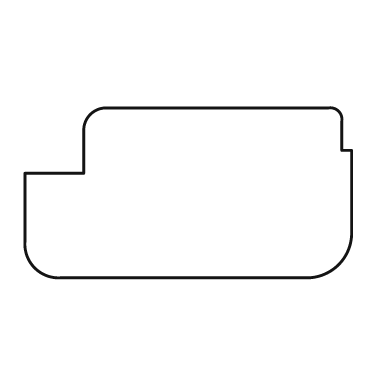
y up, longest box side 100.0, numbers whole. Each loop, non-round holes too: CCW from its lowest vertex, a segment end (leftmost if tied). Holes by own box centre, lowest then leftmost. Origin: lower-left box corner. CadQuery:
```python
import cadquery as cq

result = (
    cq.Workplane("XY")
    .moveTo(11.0, 0.0)
    .lineTo(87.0, 0.0)
    .threePointArc((96.0, 4.0), (100.0, 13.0))
    .lineTo(100.0, 39.0)
    .lineTo(97.0, 39.0)
    .lineTo(97.0, 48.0)
    .threePointArc((96.0, 51.0), (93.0, 52.0))
    .lineTo(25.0, 52.0)
    .threePointArc((20.0, 50.0), (18.0, 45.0))
    .lineTo(18.0, 32.0)
    .lineTo(0.0, 32.0)
    .lineTo(0.0, 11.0)
    .threePointArc((3.0, 3.0), (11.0, 0.0))
    .close()
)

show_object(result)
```